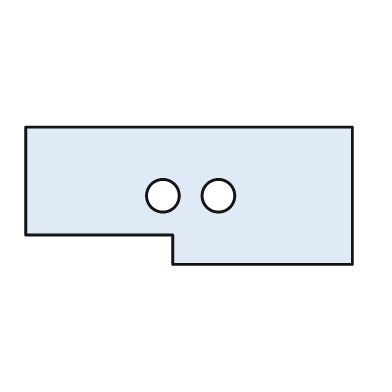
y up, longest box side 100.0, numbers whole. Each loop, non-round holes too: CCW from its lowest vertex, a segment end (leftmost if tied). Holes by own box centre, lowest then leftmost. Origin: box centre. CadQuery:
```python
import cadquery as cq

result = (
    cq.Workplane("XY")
    .moveTo(-5.0, -21.0)
    .lineTo(50.0, -21.0)
    .lineTo(50.0, 21.0)
    .lineTo(-50.0, 21.0)
    .lineTo(-50.0, -12.0)
    .lineTo(-5.0, -12.0)
    .close()
    .moveTo(-8.0, 0.0)
    .circle(5.0)
    .moveTo(9.0, 0.0)
    .circle(5.0)
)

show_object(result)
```